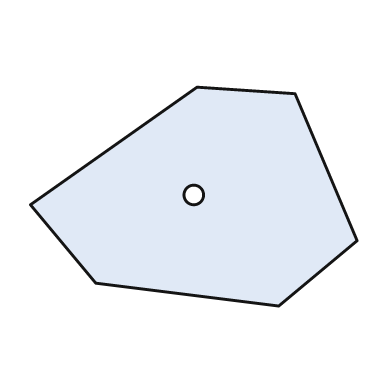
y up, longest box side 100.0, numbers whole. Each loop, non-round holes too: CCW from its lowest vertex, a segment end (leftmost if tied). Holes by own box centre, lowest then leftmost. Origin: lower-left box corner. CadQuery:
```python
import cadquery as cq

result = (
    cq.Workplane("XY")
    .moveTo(76.0, 0.0)
    .lineTo(100.0, 20.0)
    .lineTo(81.0, 65.0)
    .lineTo(51.0, 67.0)
    .lineTo(0.0, 31.0)
    .lineTo(20.0, 7.0)
    .close()
    .moveTo(50.0, 34.0)
    .circle(3.0)
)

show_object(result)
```